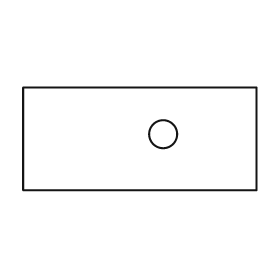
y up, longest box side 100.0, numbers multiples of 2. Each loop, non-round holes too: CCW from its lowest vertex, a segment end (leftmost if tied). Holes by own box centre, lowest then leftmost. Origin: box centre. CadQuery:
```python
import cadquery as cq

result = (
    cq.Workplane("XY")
    .moveTo(-50.0, -22.0)
    .lineTo(50.0, -22.0)
    .lineTo(50.0, 22.0)
    .lineTo(-50.0, 22.0)
    .close()
    .moveTo(10.0, 2.0)
    .circle(6.0)
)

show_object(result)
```